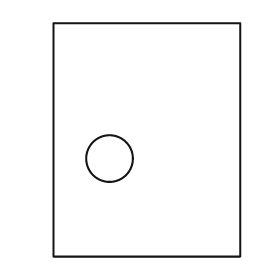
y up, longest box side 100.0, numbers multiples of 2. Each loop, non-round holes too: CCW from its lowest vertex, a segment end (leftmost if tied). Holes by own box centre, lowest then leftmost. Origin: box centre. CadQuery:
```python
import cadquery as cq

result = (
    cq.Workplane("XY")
    .moveTo(-40.0, -50.0)
    .lineTo(40.0, -50.0)
    .lineTo(40.0, 50.0)
    .lineTo(-40.0, 50.0)
    .close()
    .moveTo(-16.0, -8.0)
    .circle(10.0)
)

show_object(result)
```